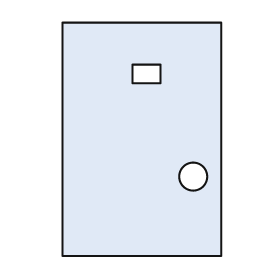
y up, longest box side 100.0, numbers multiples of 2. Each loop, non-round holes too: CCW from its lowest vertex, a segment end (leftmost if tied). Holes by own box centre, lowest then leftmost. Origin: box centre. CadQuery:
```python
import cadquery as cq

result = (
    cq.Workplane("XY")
    .moveTo(-34.0, -50.0)
    .lineTo(34.0, -50.0)
    .lineTo(34.0, 50.0)
    .lineTo(-34.0, 50.0)
    .close()
    .moveTo(22.0, -16.0)
    .circle(6.0)
    .moveTo(-4.0, 24.0)
    .lineTo(8.0, 24.0)
    .lineTo(8.0, 32.0)
    .lineTo(-4.0, 32.0)
    .close()
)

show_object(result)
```